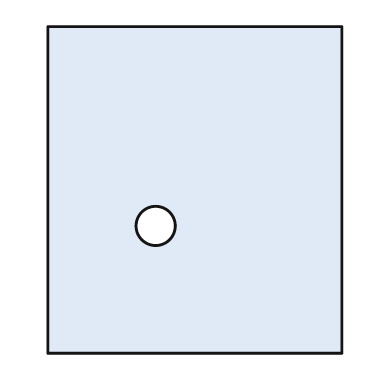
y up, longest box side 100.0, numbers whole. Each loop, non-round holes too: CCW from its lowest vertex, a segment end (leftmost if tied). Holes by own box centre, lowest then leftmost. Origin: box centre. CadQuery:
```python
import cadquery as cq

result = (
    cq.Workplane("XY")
    .moveTo(-45.0, -50.0)
    .lineTo(45.0, -50.0)
    .lineTo(45.0, 50.0)
    .lineTo(-45.0, 50.0)
    .close()
    .moveTo(-12.0, -11.0)
    .circle(6.0)
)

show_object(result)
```